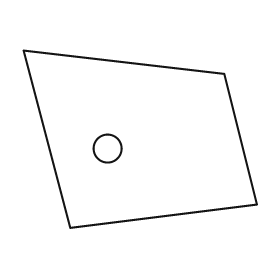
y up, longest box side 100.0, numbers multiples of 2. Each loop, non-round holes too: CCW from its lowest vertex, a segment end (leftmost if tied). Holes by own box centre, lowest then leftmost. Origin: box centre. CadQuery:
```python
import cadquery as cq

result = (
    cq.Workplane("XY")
    .moveTo(-30.0, -38.0)
    .lineTo(50.0, -28.0)
    .lineTo(36.0, 28.0)
    .lineTo(-50.0, 38.0)
    .close()
    .moveTo(-14.0, -4.0)
    .circle(6.0)
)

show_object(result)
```